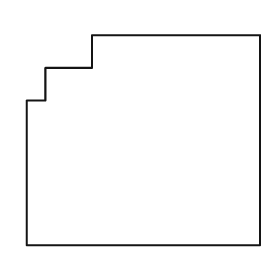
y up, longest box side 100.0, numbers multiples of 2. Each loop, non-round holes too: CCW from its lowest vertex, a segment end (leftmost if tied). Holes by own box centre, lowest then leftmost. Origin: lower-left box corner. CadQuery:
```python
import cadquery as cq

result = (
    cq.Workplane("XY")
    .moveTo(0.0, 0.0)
    .lineTo(100.0, 0.0)
    .lineTo(100.0, 90.0)
    .lineTo(28.0, 90.0)
    .lineTo(28.0, 76.0)
    .lineTo(8.0, 76.0)
    .lineTo(8.0, 62.0)
    .lineTo(0.0, 62.0)
    .close()
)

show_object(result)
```